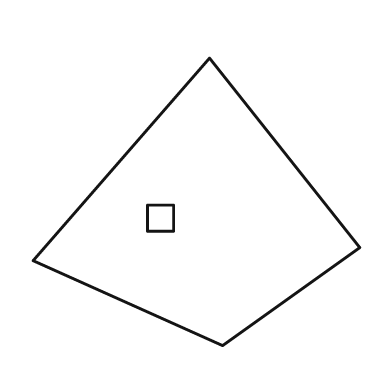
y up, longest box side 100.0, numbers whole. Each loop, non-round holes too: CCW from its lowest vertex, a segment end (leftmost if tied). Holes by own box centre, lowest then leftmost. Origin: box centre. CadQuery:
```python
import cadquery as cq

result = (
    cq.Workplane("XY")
    .moveTo(8.0, -44.0)
    .lineTo(50.0, -14.0)
    .lineTo(4.0, 44.0)
    .lineTo(-50.0, -18.0)
    .close()
    .moveTo(-15.0, -9.0)
    .lineTo(-7.0, -9.0)
    .lineTo(-7.0, -1.0)
    .lineTo(-15.0, -1.0)
    .close()
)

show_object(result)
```